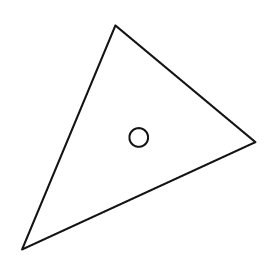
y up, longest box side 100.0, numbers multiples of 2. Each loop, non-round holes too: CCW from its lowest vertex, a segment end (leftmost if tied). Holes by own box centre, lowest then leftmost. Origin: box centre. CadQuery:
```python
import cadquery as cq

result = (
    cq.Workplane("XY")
    .moveTo(-50.0, -48.0)
    .lineTo(50.0, -2.0)
    .lineTo(-10.0, 48.0)
    .close()
    .moveTo(0.0, 0.0)
    .circle(4.0)
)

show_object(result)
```